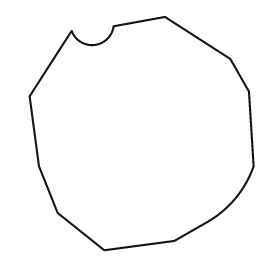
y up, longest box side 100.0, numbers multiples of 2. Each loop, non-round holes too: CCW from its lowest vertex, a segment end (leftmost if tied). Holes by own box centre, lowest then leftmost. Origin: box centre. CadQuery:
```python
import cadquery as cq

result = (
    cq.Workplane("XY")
    .moveTo(-16.0, -50.0)
    .lineTo(14.0, -46.0)
    .lineTo(28.0, -38.0)
    .threePointArc((40.0, -28.0), (48.0, -14.0))
    .lineTo(46.0, 18.0)
    .lineTo(38.0, 32.0)
    .lineTo(10.0, 50.0)
    .lineTo(-12.0, 46.0)
    .threePointArc((-20.0, 38.0), (-30.0, 44.0))
    .lineTo(-48.0, 16.0)
    .lineTo(-44.0, -14.0)
    .lineTo(-36.0, -34.0)
    .close()
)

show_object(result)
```